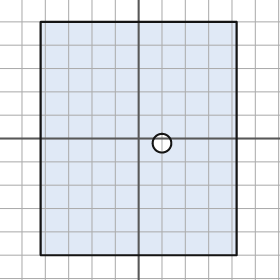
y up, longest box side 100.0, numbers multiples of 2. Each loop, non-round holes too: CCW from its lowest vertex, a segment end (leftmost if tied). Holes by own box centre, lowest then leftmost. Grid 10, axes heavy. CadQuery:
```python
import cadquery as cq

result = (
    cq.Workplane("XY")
    .moveTo(-42.0, -50.0)
    .lineTo(42.0, -50.0)
    .lineTo(42.0, 50.0)
    .lineTo(-42.0, 50.0)
    .close()
    .moveTo(10.0, -2.0)
    .circle(4.0)
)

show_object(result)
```